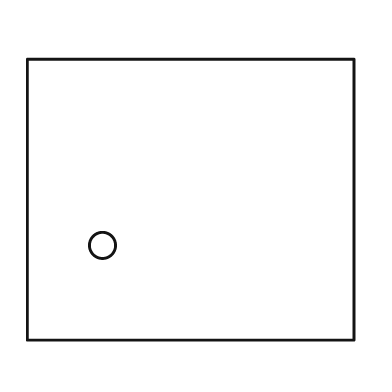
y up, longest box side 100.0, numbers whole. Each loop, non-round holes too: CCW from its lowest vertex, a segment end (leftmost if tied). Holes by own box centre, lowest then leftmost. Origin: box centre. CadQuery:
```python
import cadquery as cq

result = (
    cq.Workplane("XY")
    .moveTo(-50.0, -43.0)
    .lineTo(50.0, -43.0)
    .lineTo(50.0, 43.0)
    .lineTo(-50.0, 43.0)
    .close()
    .moveTo(-27.0, -14.0)
    .circle(4.0)
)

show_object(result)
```